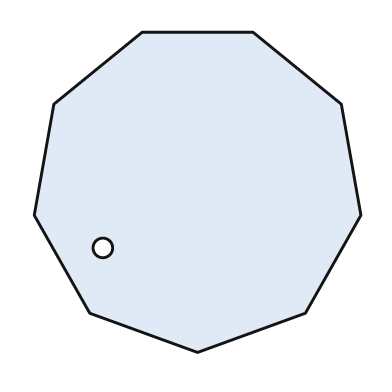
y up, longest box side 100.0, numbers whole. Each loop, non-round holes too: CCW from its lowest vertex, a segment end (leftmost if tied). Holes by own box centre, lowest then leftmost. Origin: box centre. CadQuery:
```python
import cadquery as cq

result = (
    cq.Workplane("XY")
    .moveTo(0.0, -49.0)
    .lineTo(33.0, -37.0)
    .lineTo(50.0, -7.0)
    .lineTo(44.0, 27.0)
    .lineTo(17.0, 49.0)
    .lineTo(-17.0, 49.0)
    .lineTo(-44.0, 27.0)
    .lineTo(-50.0, -7.0)
    .lineTo(-33.0, -37.0)
    .close()
    .moveTo(-29.0, -17.0)
    .circle(3.0)
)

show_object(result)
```